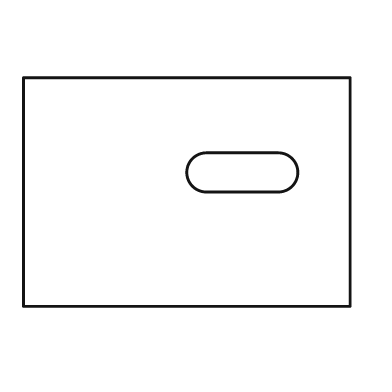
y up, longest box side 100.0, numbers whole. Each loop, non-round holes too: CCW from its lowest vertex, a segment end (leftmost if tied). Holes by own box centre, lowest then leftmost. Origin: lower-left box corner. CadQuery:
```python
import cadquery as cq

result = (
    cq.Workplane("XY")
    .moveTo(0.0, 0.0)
    .lineTo(100.0, 0.0)
    .lineTo(100.0, 70.0)
    .lineTo(0.0, 70.0)
    .close()
    .moveTo(56.0, 35.0)
    .lineTo(78.0, 35.0)
    .threePointArc((84.0, 41.0), (78.0, 47.0))
    .lineTo(56.0, 47.0)
    .threePointArc((50.0, 41.0), (56.0, 35.0))
    .close()
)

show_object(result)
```